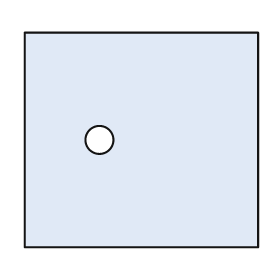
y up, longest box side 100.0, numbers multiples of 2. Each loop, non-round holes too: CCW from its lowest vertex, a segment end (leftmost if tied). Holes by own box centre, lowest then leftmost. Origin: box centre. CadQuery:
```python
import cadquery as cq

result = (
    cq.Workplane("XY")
    .moveTo(-50.0, -46.0)
    .lineTo(50.0, -46.0)
    .lineTo(50.0, 46.0)
    .lineTo(-50.0, 46.0)
    .close()
    .moveTo(-18.0, 0.0)
    .circle(6.0)
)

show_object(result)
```